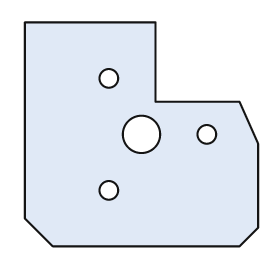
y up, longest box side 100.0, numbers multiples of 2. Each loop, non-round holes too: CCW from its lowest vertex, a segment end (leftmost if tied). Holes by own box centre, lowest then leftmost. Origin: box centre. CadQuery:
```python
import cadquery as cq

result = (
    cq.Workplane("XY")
    .moveTo(-38.0, -48.0)
    .lineTo(42.0, -48.0)
    .lineTo(50.0, -40.0)
    .lineTo(50.0, -4.0)
    .lineTo(42.0, 14.0)
    .lineTo(6.0, 14.0)
    .lineTo(6.0, 48.0)
    .lineTo(-50.0, 48.0)
    .lineTo(-50.0, -36.0)
    .close()
    .moveTo(-14.0, -24.0)
    .circle(4.0)
    .moveTo(0.0, 0.0)
    .circle(8.0)
    .moveTo(28.0, 0.0)
    .circle(4.0)
    .moveTo(-14.0, 24.0)
    .circle(4.0)
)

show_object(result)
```